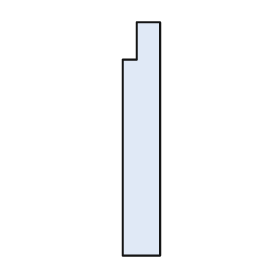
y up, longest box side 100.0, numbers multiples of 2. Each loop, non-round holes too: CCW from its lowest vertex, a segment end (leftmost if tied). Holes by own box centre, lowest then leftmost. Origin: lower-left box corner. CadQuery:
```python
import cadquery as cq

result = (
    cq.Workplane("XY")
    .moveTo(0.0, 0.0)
    .lineTo(16.0, 0.0)
    .lineTo(16.0, 100.0)
    .lineTo(6.0, 100.0)
    .lineTo(6.0, 84.0)
    .lineTo(0.0, 84.0)
    .close()
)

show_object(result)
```